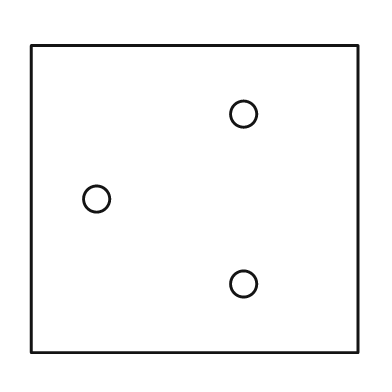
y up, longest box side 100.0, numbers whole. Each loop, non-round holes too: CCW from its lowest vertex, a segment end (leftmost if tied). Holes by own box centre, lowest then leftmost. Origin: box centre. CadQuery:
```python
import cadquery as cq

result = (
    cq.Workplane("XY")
    .moveTo(-50.0, -47.0)
    .lineTo(50.0, -47.0)
    .lineTo(50.0, 47.0)
    .lineTo(-50.0, 47.0)
    .close()
    .moveTo(15.0, -26.0)
    .circle(4.0)
    .moveTo(-30.0, 0.0)
    .circle(4.0)
    .moveTo(15.0, 26.0)
    .circle(4.0)
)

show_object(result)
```